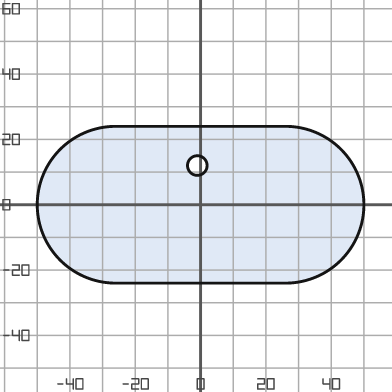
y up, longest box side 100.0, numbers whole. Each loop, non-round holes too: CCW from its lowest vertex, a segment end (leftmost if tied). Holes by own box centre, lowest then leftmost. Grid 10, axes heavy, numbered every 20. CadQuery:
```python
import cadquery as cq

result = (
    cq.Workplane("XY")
    .moveTo(-26.0, -24.0)
    .lineTo(26.0, -24.0)
    .threePointArc((50.0, 0.0), (26.0, 24.0))
    .lineTo(-26.0, 24.0)
    .threePointArc((-50.0, 0.0), (-26.0, -24.0))
    .close()
    .moveTo(-1.0, 12.0)
    .circle(3.0)
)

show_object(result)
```